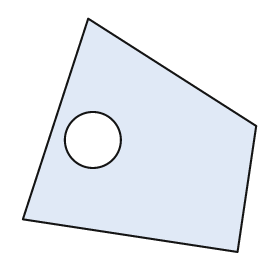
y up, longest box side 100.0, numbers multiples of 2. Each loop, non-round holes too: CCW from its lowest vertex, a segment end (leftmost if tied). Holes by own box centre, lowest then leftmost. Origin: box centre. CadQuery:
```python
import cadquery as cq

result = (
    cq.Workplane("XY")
    .moveTo(42.0, -50.0)
    .lineTo(50.0, 4.0)
    .lineTo(-22.0, 50.0)
    .lineTo(-50.0, -36.0)
    .close()
    .moveTo(-20.0, -2.0)
    .circle(12.0)
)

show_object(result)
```